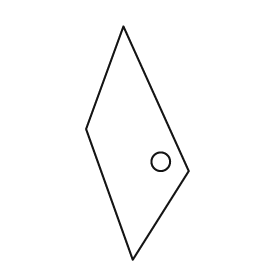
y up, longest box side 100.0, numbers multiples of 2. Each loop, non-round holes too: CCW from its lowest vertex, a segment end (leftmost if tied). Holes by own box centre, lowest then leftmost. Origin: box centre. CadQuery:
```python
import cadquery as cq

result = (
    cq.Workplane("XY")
    .moveTo(-2.0, -50.0)
    .lineTo(22.0, -12.0)
    .lineTo(-6.0, 50.0)
    .lineTo(-22.0, 6.0)
    .close()
    .moveTo(10.0, -8.0)
    .circle(4.0)
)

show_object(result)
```